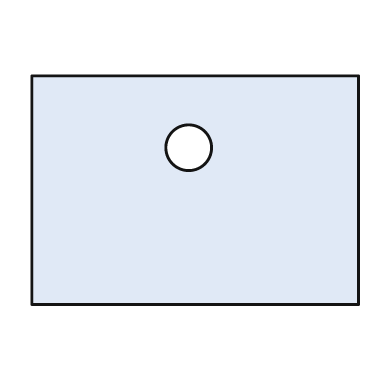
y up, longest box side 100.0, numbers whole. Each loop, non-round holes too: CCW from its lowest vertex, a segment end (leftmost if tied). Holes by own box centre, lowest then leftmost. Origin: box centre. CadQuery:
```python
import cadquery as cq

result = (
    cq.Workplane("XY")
    .moveTo(-50.0, -35.0)
    .lineTo(50.0, -35.0)
    .lineTo(50.0, 35.0)
    .lineTo(-50.0, 35.0)
    .close()
    .moveTo(-2.0, 13.0)
    .circle(7.0)
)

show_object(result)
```